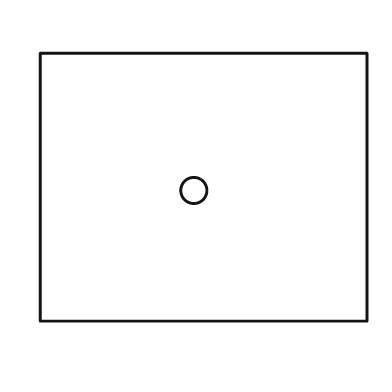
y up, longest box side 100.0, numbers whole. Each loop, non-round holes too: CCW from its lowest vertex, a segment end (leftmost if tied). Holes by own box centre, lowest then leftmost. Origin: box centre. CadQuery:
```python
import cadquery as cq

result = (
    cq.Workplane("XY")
    .moveTo(-50.0, -41.0)
    .lineTo(50.0, -41.0)
    .lineTo(50.0, 41.0)
    .lineTo(-50.0, 41.0)
    .close()
    .moveTo(-3.0, -1.0)
    .circle(4.0)
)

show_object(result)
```